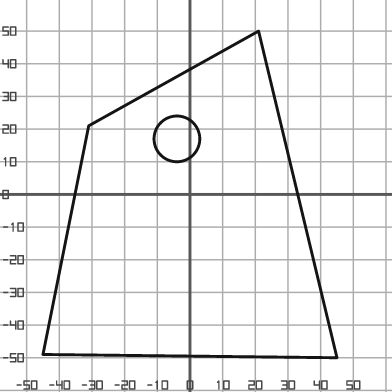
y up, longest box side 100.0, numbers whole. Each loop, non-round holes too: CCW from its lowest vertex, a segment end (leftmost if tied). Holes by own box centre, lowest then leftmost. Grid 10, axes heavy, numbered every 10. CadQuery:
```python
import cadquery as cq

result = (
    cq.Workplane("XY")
    .moveTo(45.0, -50.0)
    .lineTo(21.0, 50.0)
    .lineTo(-31.0, 21.0)
    .lineTo(-45.0, -49.0)
    .close()
    .moveTo(-4.0, 17.0)
    .circle(7.0)
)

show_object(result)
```